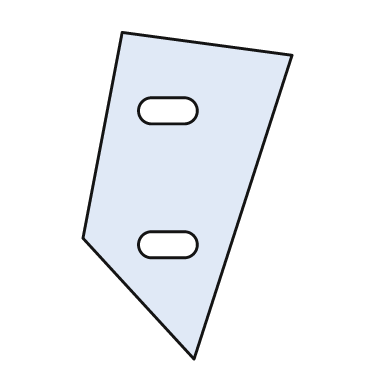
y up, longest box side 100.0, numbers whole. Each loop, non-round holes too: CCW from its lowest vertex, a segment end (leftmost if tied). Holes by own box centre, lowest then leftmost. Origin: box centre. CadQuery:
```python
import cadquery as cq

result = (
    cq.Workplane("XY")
    .moveTo(2.0, -50.0)
    .lineTo(32.0, 43.0)
    .lineTo(-20.0, 50.0)
    .lineTo(-32.0, -13.0)
    .close()
    .moveTo(-11.0, -19.0)
    .lineTo(-1.0, -19.0)
    .threePointArc((3.0, -15.0), (-1.0, -11.0))
    .lineTo(-11.0, -11.0)
    .threePointArc((-15.0, -15.0), (-11.0, -19.0))
    .close()
    .moveTo(-11.0, 22.0)
    .lineTo(-1.0, 22.0)
    .threePointArc((3.0, 26.0), (-1.0, 30.0))
    .lineTo(-11.0, 30.0)
    .threePointArc((-15.0, 26.0), (-11.0, 22.0))
    .close()
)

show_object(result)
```